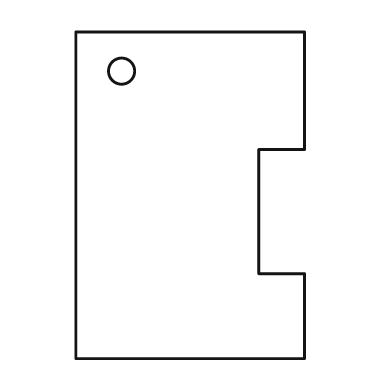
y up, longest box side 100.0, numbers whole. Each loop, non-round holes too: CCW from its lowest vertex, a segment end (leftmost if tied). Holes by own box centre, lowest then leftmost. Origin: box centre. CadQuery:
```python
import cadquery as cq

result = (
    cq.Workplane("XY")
    .moveTo(-35.0, -50.0)
    .lineTo(35.0, -50.0)
    .lineTo(35.0, -24.0)
    .lineTo(21.0, -24.0)
    .lineTo(21.0, 14.0)
    .lineTo(35.0, 14.0)
    .lineTo(35.0, 50.0)
    .lineTo(-35.0, 50.0)
    .close()
    .moveTo(-21.0, 38.0)
    .circle(4.0)
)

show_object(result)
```